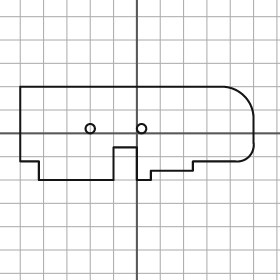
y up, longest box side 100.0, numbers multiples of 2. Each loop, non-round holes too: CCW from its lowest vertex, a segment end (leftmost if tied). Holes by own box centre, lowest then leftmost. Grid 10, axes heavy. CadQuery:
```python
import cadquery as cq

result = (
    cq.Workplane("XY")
    .moveTo(-42.0, -20.0)
    .lineTo(-10.0, -20.0)
    .lineTo(-10.0, -6.0)
    .lineTo(0.0, -6.0)
    .lineTo(0.0, -20.0)
    .lineTo(6.0, -20.0)
    .lineTo(6.0, -16.0)
    .lineTo(24.0, -16.0)
    .lineTo(24.0, -12.0)
    .lineTo(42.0, -12.0)
    .threePointArc((48.0, -10.0), (50.0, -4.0))
    .lineTo(50.0, 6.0)
    .threePointArc((46.0, 16.0), (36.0, 20.0))
    .lineTo(-50.0, 20.0)
    .lineTo(-50.0, -12.0)
    .lineTo(-42.0, -12.0)
    .close()
    .moveTo(-20.0, 2.0)
    .circle(2.0)
    .moveTo(2.0, 2.0)
    .circle(2.0)
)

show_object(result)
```